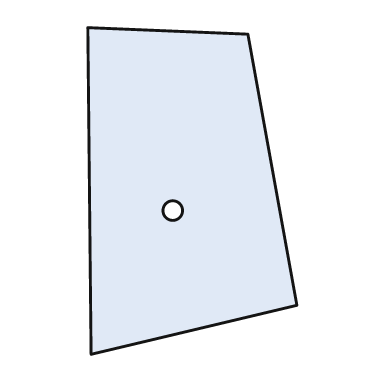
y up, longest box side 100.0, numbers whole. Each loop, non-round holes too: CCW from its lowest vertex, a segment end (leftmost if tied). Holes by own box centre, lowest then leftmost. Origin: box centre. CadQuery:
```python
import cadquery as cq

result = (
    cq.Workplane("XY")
    .moveTo(-31.0, -50.0)
    .lineTo(32.0, -35.0)
    .lineTo(17.0, 48.0)
    .lineTo(-32.0, 50.0)
    .close()
    .moveTo(-6.0, -6.0)
    .circle(3.0)
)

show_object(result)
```